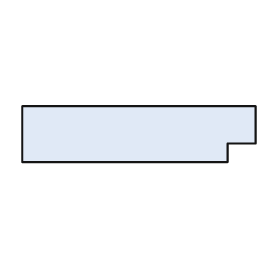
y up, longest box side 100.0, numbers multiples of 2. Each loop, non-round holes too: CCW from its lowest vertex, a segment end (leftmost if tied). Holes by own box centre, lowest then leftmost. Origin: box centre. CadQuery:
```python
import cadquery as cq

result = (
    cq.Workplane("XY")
    .moveTo(-50.0, -12.0)
    .lineTo(38.0, -12.0)
    .lineTo(38.0, -4.0)
    .lineTo(50.0, -4.0)
    .lineTo(50.0, 12.0)
    .lineTo(-50.0, 12.0)
    .close()
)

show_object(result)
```